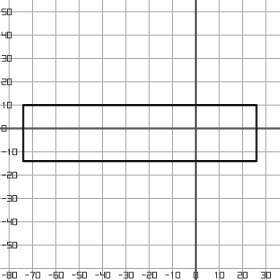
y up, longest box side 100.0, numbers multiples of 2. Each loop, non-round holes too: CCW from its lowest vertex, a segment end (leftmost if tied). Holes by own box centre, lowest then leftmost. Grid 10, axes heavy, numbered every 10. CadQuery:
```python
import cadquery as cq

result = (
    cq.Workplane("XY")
    .moveTo(-74.0, -14.0)
    .lineTo(26.0, -14.0)
    .lineTo(26.0, 10.0)
    .lineTo(-74.0, 10.0)
    .close()
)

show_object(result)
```